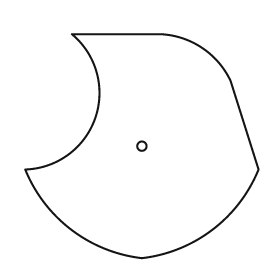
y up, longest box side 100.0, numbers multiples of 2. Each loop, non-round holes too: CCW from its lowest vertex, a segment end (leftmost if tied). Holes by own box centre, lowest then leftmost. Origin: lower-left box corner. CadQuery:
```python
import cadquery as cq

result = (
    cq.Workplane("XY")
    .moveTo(50.0, 0.0)
    .threePointArc((80.0, 12.0), (100.0, 38.0))
    .lineTo(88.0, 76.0)
    .threePointArc((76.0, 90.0), (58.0, 96.0))
    .lineTo(20.0, 96.0)
    .threePointArc((30.0, 60.0), (0.0, 38.0))
    .threePointArc((20.0, 12.0), (50.0, 0.0))
    .close()
    .moveTo(50.0, 48.0)
    .circle(2.0)
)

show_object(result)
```